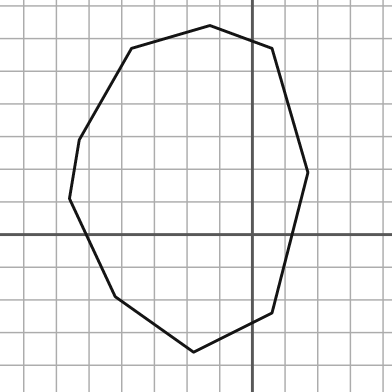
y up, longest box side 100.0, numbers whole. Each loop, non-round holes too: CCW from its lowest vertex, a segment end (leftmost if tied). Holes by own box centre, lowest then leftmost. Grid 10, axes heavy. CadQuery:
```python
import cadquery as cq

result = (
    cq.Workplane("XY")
    .moveTo(-18.0, -36.0)
    .lineTo(6.0, -24.0)
    .lineTo(17.0, 19.0)
    .lineTo(6.0, 57.0)
    .lineTo(-13.0, 64.0)
    .lineTo(-37.0, 57.0)
    .lineTo(-53.0, 29.0)
    .lineTo(-56.0, 11.0)
    .lineTo(-42.0, -19.0)
    .close()
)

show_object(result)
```